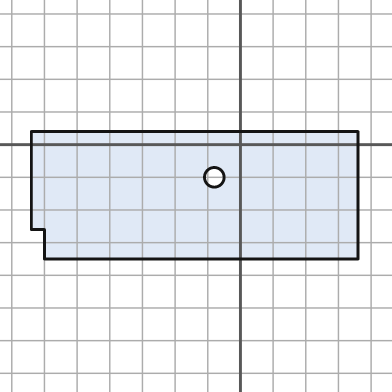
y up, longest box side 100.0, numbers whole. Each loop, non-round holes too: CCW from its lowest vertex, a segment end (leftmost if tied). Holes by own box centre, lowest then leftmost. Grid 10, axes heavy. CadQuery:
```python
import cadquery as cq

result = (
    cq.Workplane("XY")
    .moveTo(-60.0, -35.0)
    .lineTo(36.0, -35.0)
    .lineTo(36.0, 4.0)
    .lineTo(-64.0, 4.0)
    .lineTo(-64.0, -26.0)
    .lineTo(-60.0, -26.0)
    .close()
    .moveTo(-8.0, -10.0)
    .circle(3.0)
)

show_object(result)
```